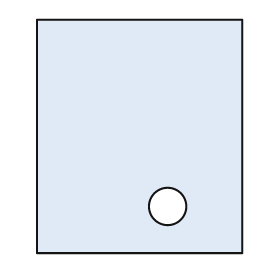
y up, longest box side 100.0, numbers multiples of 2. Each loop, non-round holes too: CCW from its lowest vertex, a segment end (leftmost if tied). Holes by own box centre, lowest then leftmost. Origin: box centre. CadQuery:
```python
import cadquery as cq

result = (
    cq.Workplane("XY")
    .moveTo(-44.0, -50.0)
    .lineTo(44.0, -50.0)
    .lineTo(44.0, 50.0)
    .lineTo(-44.0, 50.0)
    .close()
    .moveTo(12.0, -30.0)
    .circle(8.0)
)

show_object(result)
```